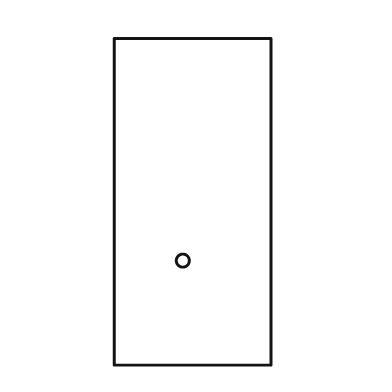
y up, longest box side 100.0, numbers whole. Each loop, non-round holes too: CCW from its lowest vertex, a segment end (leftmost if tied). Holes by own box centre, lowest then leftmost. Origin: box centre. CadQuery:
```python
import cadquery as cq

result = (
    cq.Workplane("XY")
    .moveTo(-24.0, -50.0)
    .lineTo(24.0, -50.0)
    .lineTo(24.0, 50.0)
    .lineTo(-24.0, 50.0)
    .close()
    .moveTo(-3.0, -18.0)
    .circle(2.0)
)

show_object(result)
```